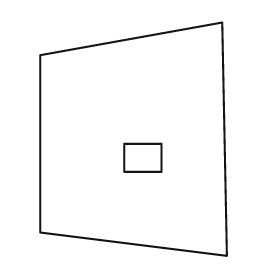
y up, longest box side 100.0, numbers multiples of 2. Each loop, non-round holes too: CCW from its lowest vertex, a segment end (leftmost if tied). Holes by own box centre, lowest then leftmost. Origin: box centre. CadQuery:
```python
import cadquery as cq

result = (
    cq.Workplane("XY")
    .moveTo(40.0, -50.0)
    .lineTo(38.0, 50.0)
    .lineTo(-40.0, 36.0)
    .lineTo(-40.0, -40.0)
    .close()
    .moveTo(-4.0, -14.0)
    .lineTo(12.0, -14.0)
    .lineTo(12.0, -2.0)
    .lineTo(-4.0, -2.0)
    .close()
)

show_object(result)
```